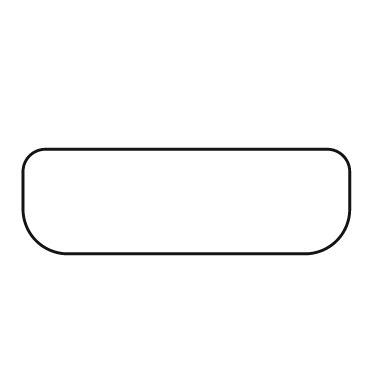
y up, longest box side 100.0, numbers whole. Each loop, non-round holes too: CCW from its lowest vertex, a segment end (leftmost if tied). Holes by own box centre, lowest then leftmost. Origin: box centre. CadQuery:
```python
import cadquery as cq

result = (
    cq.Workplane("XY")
    .moveTo(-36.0, -16.0)
    .lineTo(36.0, -16.0)
    .threePointArc((46.0, -12.0), (50.0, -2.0))
    .lineTo(50.0, 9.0)
    .threePointArc((48.0, 14.0), (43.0, 16.0))
    .lineTo(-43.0, 16.0)
    .threePointArc((-48.0, 14.0), (-50.0, 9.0))
    .lineTo(-50.0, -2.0)
    .threePointArc((-46.0, -12.0), (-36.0, -16.0))
    .close()
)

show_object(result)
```